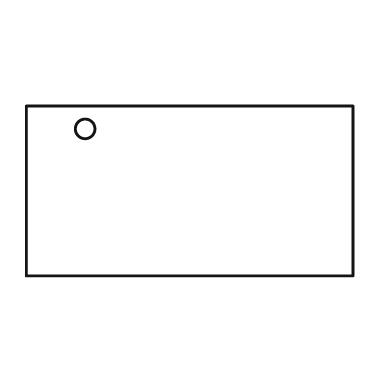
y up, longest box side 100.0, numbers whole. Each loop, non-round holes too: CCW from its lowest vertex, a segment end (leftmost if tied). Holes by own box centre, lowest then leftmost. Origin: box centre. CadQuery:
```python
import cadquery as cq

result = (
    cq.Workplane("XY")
    .moveTo(-50.0, -26.0)
    .lineTo(50.0, -26.0)
    .lineTo(50.0, 26.0)
    .lineTo(-50.0, 26.0)
    .close()
    .moveTo(-32.0, 19.0)
    .circle(3.0)
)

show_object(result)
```